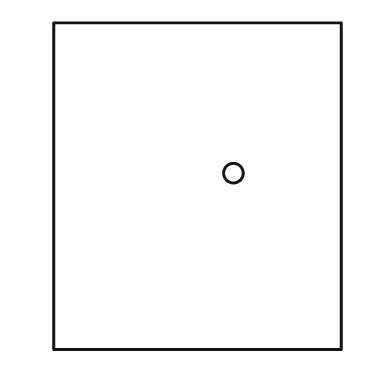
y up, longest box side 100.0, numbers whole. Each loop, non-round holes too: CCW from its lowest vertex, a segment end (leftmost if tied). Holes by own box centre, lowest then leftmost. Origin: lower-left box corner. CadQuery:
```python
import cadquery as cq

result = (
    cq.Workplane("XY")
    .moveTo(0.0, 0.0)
    .lineTo(88.0, 0.0)
    .lineTo(88.0, 100.0)
    .lineTo(0.0, 100.0)
    .close()
    .moveTo(55.0, 54.0)
    .circle(3.0)
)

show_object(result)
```